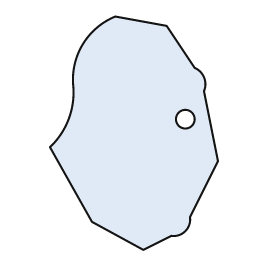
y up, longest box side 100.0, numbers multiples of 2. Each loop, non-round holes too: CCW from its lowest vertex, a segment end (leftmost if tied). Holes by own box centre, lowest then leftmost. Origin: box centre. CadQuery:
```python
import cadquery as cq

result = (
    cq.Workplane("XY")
    .moveTo(4.0, -50.0)
    .lineTo(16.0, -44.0)
    .threePointArc((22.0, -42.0), (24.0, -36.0))
    .lineTo(36.0, -12.0)
    .lineTo(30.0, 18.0)
    .threePointArc((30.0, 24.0), (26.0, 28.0))
    .lineTo(14.0, 46.0)
    .lineTo(-8.0, 50.0)
    .threePointArc((-22.0, 38.0), (-26.0, 20.0))
    .threePointArc((-28.0, 6.0), (-36.0, -6.0))
    .lineTo(-18.0, -38.0)
    .close()
    .moveTo(22.0, 6.0)
    .circle(4.0)
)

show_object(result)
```